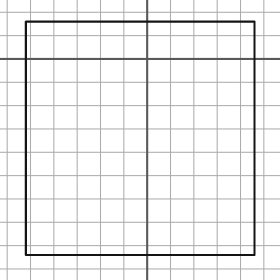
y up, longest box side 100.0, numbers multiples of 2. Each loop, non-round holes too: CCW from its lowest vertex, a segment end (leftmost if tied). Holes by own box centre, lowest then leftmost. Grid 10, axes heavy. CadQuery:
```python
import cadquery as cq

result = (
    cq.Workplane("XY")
    .moveTo(-52.0, -84.0)
    .lineTo(46.0, -84.0)
    .lineTo(46.0, 16.0)
    .lineTo(-52.0, 16.0)
    .close()
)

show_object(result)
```